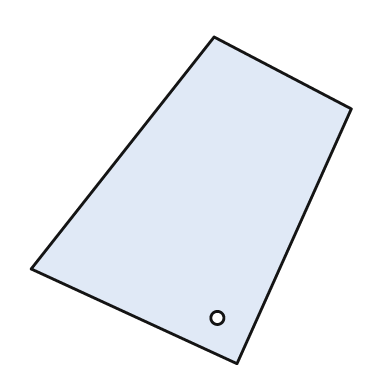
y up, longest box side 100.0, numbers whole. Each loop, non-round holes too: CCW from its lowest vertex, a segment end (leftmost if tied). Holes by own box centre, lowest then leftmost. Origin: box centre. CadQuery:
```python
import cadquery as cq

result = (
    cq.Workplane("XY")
    .moveTo(14.0, -50.0)
    .lineTo(49.0, 28.0)
    .lineTo(7.0, 50.0)
    .lineTo(-49.0, -21.0)
    .close()
    .moveTo(8.0, -36.0)
    .circle(2.0)
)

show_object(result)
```